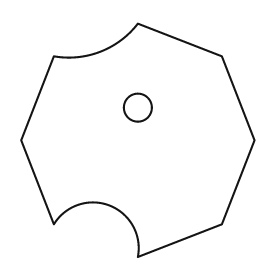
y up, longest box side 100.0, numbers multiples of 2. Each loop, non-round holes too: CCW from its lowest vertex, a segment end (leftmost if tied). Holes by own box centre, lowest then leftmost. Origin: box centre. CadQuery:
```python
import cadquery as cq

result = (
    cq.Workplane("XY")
    .moveTo(0.0, -50.0)
    .lineTo(36.0, -36.0)
    .lineTo(50.0, 0.0)
    .lineTo(36.0, 36.0)
    .lineTo(0.0, 50.0)
    .threePointArc((-16.0, 38.0), (-36.0, 36.0))
    .lineTo(-50.0, 0.0)
    .lineTo(-36.0, -36.0)
    .threePointArc((-12.0, -28.0), (0.0, -50.0))
    .close()
    .moveTo(0.0, 14.0)
    .circle(6.0)
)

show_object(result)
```